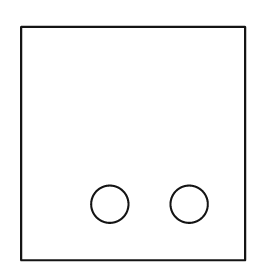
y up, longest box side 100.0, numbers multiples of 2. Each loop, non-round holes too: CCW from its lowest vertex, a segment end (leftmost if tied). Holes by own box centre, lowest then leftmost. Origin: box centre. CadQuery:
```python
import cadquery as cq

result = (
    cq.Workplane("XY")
    .moveTo(-48.0, -50.0)
    .lineTo(48.0, -50.0)
    .lineTo(48.0, 50.0)
    .lineTo(-48.0, 50.0)
    .close()
    .moveTo(-10.0, -26.0)
    .circle(8.0)
    .moveTo(24.0, -26.0)
    .circle(8.0)
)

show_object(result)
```